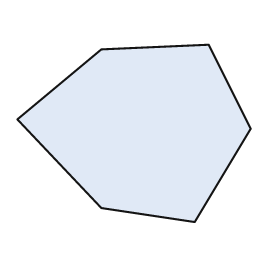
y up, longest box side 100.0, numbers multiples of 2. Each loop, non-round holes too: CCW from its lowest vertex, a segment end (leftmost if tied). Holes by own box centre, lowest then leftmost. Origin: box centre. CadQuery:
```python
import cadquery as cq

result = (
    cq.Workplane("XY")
    .moveTo(26.0, -38.0)
    .lineTo(50.0, 2.0)
    .lineTo(32.0, 38.0)
    .lineTo(-14.0, 36.0)
    .lineTo(-50.0, 6.0)
    .lineTo(-14.0, -32.0)
    .close()
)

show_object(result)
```